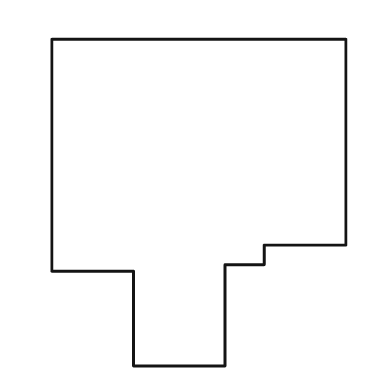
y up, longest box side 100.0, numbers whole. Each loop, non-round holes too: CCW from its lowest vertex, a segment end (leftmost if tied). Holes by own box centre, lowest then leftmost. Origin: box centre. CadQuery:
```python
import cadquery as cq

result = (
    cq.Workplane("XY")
    .moveTo(-20.0, -50.0)
    .lineTo(8.0, -50.0)
    .lineTo(8.0, -19.0)
    .lineTo(20.0, -19.0)
    .lineTo(20.0, -13.0)
    .lineTo(45.0, -13.0)
    .lineTo(45.0, 50.0)
    .lineTo(-45.0, 50.0)
    .lineTo(-45.0, -21.0)
    .lineTo(-20.0, -21.0)
    .close()
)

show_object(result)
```